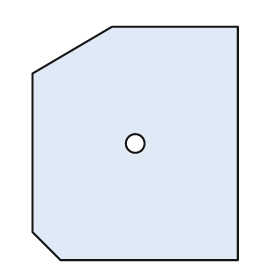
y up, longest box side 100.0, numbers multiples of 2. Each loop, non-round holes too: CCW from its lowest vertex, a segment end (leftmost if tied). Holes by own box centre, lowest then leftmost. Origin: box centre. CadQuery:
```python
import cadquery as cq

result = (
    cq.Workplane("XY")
    .moveTo(-32.0, -50.0)
    .lineTo(44.0, -50.0)
    .lineTo(44.0, 50.0)
    .lineTo(-10.0, 50.0)
    .lineTo(-44.0, 30.0)
    .lineTo(-44.0, -38.0)
    .close()
    .moveTo(0.0, 0.0)
    .circle(4.0)
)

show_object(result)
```